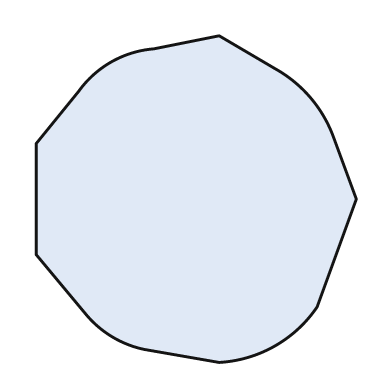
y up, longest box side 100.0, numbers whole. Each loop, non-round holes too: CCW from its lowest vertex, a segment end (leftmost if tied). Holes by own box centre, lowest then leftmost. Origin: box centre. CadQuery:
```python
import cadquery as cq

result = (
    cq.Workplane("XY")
    .moveTo(7.0, -50.0)
    .threePointArc((24.0, -45.0), (37.0, -33.0))
    .lineTo(49.0, 0.0)
    .lineTo(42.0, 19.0)
    .threePointArc((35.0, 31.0), (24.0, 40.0))
    .lineTo(7.0, 50.0)
    .lineTo(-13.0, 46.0)
    .threePointArc((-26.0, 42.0), (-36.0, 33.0))
    .lineTo(-49.0, 17.0)
    .lineTo(-49.0, -17.0)
    .lineTo(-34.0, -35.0)
    .threePointArc((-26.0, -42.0), (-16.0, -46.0))
    .close()
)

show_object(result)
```